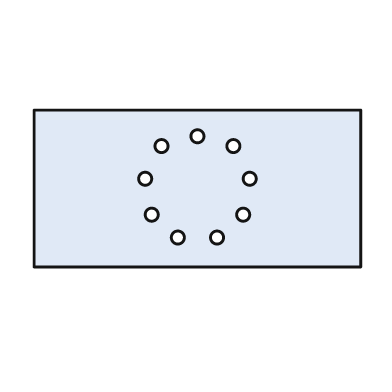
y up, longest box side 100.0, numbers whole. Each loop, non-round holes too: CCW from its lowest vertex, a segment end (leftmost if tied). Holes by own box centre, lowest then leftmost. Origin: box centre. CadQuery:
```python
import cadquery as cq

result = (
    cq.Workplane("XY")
    .moveTo(-50.0, -24.0)
    .lineTo(50.0, -24.0)
    .lineTo(50.0, 24.0)
    .lineTo(-50.0, 24.0)
    .close()
    .moveTo(-6.0, -15.0)
    .circle(2.0)
    .moveTo(6.0, -15.0)
    .circle(2.0)
    .moveTo(-14.0, -8.0)
    .circle(2.0)
    .moveTo(14.0, -8.0)
    .circle(2.0)
    .moveTo(-16.0, 3.0)
    .circle(2.0)
    .moveTo(16.0, 3.0)
    .circle(2.0)
    .moveTo(-11.0, 13.0)
    .circle(2.0)
    .moveTo(11.0, 13.0)
    .circle(2.0)
    .moveTo(0.0, 16.0)
    .circle(2.0)
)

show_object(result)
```